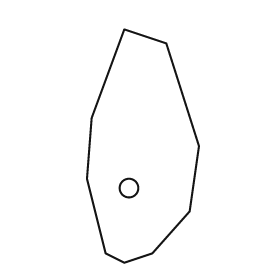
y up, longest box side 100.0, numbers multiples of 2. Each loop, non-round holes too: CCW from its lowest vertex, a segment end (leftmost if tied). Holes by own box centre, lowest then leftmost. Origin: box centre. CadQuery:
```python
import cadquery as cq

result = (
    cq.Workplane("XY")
    .moveTo(-8.0, -50.0)
    .lineTo(4.0, -46.0)
    .lineTo(20.0, -28.0)
    .lineTo(24.0, 0.0)
    .lineTo(10.0, 44.0)
    .lineTo(-8.0, 50.0)
    .lineTo(-22.0, 12.0)
    .lineTo(-24.0, -14.0)
    .lineTo(-16.0, -46.0)
    .close()
    .moveTo(-6.0, -18.0)
    .circle(4.0)
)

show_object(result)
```